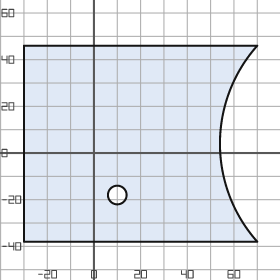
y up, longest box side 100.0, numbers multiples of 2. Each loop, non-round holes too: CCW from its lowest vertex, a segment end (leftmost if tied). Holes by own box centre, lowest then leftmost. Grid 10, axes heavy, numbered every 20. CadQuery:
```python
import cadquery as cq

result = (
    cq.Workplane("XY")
    .moveTo(-30.0, -38.0)
    .lineTo(70.0, -38.0)
    .threePointArc((54.0, 4.0), (70.0, 46.0))
    .lineTo(-30.0, 46.0)
    .close()
    .moveTo(10.0, -18.0)
    .circle(4.0)
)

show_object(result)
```